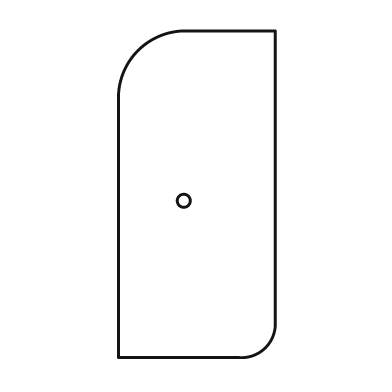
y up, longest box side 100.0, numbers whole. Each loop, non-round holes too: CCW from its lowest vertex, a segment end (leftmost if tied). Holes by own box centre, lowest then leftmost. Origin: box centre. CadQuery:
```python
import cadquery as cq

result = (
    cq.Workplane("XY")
    .moveTo(-24.0, -50.0)
    .lineTo(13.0, -50.0)
    .threePointArc((21.0, -47.0), (24.0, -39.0))
    .lineTo(24.0, 50.0)
    .lineTo(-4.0, 50.0)
    .threePointArc((-18.0, 44.0), (-24.0, 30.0))
    .close()
    .moveTo(-4.0, -2.0)
    .circle(2.0)
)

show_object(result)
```